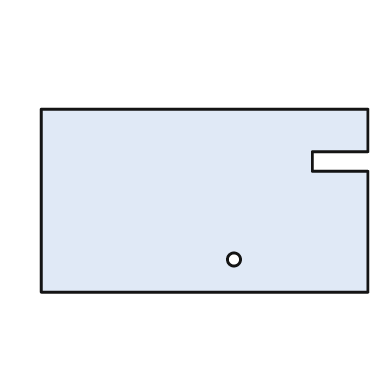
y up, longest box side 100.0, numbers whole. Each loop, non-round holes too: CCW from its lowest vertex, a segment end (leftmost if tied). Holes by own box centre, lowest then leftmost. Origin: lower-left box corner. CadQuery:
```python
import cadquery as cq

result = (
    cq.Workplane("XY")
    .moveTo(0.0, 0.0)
    .lineTo(100.0, 0.0)
    .lineTo(100.0, 37.0)
    .lineTo(83.0, 37.0)
    .lineTo(83.0, 43.0)
    .lineTo(100.0, 43.0)
    .lineTo(100.0, 56.0)
    .lineTo(0.0, 56.0)
    .close()
    .moveTo(59.0, 10.0)
    .circle(2.0)
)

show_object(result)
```